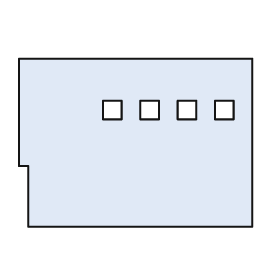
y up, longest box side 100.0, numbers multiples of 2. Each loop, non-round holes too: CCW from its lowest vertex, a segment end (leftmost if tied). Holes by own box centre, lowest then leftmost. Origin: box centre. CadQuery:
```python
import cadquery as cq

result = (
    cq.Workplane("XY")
    .moveTo(-46.0, -36.0)
    .lineTo(50.0, -36.0)
    .lineTo(50.0, 36.0)
    .lineTo(-50.0, 36.0)
    .lineTo(-50.0, -10.0)
    .lineTo(-46.0, -10.0)
    .close()
    .moveTo(-14.0, 10.0)
    .lineTo(-6.0, 10.0)
    .lineTo(-6.0, 18.0)
    .lineTo(-14.0, 18.0)
    .close()
    .moveTo(2.0, 10.0)
    .lineTo(10.0, 10.0)
    .lineTo(10.0, 18.0)
    .lineTo(2.0, 18.0)
    .close()
    .moveTo(18.0, 10.0)
    .lineTo(26.0, 10.0)
    .lineTo(26.0, 18.0)
    .lineTo(18.0, 18.0)
    .close()
    .moveTo(34.0, 10.0)
    .lineTo(42.0, 10.0)
    .lineTo(42.0, 18.0)
    .lineTo(34.0, 18.0)
    .close()
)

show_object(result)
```